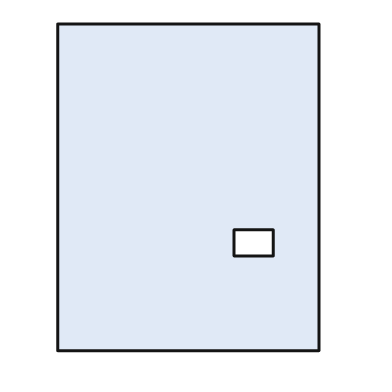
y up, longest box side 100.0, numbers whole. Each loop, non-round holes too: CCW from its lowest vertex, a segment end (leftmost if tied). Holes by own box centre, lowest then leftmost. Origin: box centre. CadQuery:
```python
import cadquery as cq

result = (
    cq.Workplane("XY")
    .moveTo(-40.0, -50.0)
    .lineTo(40.0, -50.0)
    .lineTo(40.0, 50.0)
    .lineTo(-40.0, 50.0)
    .close()
    .moveTo(14.0, -21.0)
    .lineTo(26.0, -21.0)
    .lineTo(26.0, -13.0)
    .lineTo(14.0, -13.0)
    .close()
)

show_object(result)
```